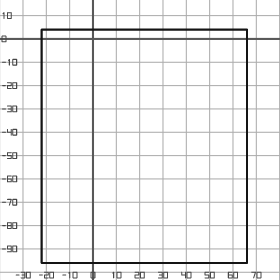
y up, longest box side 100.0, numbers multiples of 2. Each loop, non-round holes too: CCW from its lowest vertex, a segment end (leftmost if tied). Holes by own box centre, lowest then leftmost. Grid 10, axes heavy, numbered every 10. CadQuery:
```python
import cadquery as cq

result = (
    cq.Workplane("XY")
    .moveTo(-22.0, -96.0)
    .lineTo(66.0, -96.0)
    .lineTo(66.0, 4.0)
    .lineTo(-22.0, 4.0)
    .close()
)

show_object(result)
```